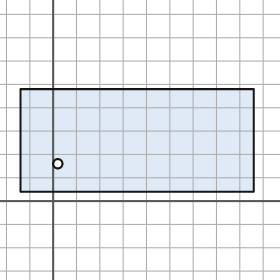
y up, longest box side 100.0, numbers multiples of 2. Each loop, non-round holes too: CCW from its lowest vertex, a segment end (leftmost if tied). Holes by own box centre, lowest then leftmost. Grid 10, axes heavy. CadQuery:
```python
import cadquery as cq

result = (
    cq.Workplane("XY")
    .moveTo(-14.0, 4.0)
    .lineTo(86.0, 4.0)
    .lineTo(86.0, 48.0)
    .lineTo(-14.0, 48.0)
    .close()
    .moveTo(2.0, 16.0)
    .circle(2.0)
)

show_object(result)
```